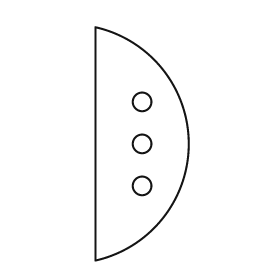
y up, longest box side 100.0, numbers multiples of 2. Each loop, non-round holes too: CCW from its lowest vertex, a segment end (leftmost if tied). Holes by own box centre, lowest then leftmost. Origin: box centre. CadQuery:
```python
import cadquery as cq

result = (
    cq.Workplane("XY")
    .moveTo(-20.0, -50.0)
    .threePointArc((20.0, 0.0), (-20.0, 50.0))
    .close()
    .moveTo(0.0, -18.0)
    .circle(4.0)
    .moveTo(0.0, 0.0)
    .circle(4.0)
    .moveTo(0.0, 18.0)
    .circle(4.0)
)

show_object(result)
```